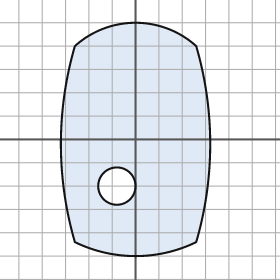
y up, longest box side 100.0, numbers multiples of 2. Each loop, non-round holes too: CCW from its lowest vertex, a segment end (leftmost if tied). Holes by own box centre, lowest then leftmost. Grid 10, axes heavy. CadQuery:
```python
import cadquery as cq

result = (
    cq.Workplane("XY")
    .moveTo(-26.0, -44.0)
    .threePointArc((0.0, -50.0), (26.0, -44.0))
    .threePointArc((32.0, -2.0), (26.0, 40.0))
    .threePointArc((0.0, 50.0), (-26.0, 40.0))
    .threePointArc((-32.0, -2.0), (-26.0, -44.0))
    .close()
    .moveTo(-8.0, -20.0)
    .circle(8.0)
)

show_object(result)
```